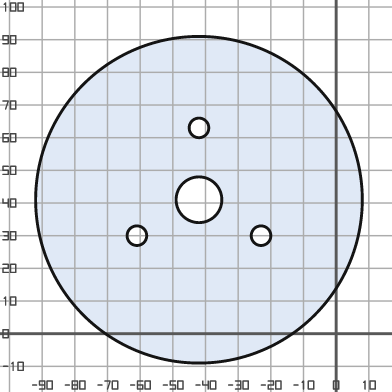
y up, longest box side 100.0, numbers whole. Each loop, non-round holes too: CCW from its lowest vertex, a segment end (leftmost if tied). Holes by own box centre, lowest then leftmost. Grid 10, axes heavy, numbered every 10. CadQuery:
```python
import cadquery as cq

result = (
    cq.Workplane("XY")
    .moveTo(-42.0, 41.0)
    .circle(50.0)
    .moveTo(-61.0, 30.0)
    .circle(3.0)
    .moveTo(-23.0, 30.0)
    .circle(3.0)
    .moveTo(-42.0, 41.0)
    .circle(7.0)
    .moveTo(-42.0, 63.0)
    .circle(3.0)
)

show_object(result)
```